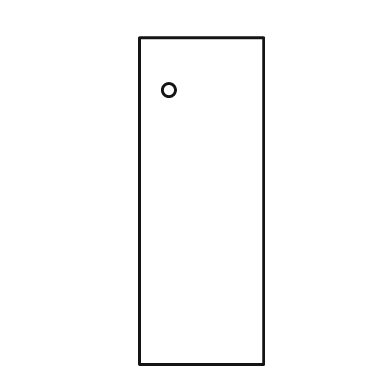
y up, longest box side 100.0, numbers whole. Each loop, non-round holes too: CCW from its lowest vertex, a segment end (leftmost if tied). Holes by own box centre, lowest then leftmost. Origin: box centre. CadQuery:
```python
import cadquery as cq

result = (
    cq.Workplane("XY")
    .moveTo(-19.0, -50.0)
    .lineTo(19.0, -50.0)
    .lineTo(19.0, 50.0)
    .lineTo(-19.0, 50.0)
    .close()
    .moveTo(-10.0, 34.0)
    .circle(2.0)
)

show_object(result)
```